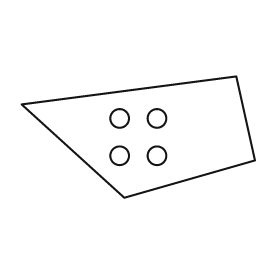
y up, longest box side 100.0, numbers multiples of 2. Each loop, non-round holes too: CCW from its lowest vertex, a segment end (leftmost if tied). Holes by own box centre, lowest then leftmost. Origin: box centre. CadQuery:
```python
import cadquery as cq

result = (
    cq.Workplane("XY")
    .moveTo(-6.0, -26.0)
    .lineTo(50.0, -10.0)
    .lineTo(42.0, 26.0)
    .lineTo(-50.0, 14.0)
    .close()
    .moveTo(-8.0, -8.0)
    .circle(4.0)
    .moveTo(8.0, -8.0)
    .circle(4.0)
    .moveTo(-8.0, 8.0)
    .circle(4.0)
    .moveTo(8.0, 8.0)
    .circle(4.0)
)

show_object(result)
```